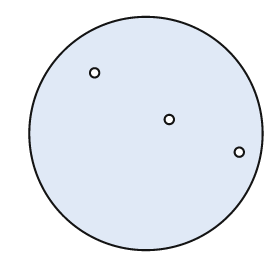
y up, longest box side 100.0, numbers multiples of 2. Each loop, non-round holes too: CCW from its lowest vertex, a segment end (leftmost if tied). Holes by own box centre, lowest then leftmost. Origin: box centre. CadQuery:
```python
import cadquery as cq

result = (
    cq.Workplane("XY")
    .moveTo(0.0, 0.0)
    .circle(50.0)
    .moveTo(40.0, -8.0)
    .circle(2.0)
    .moveTo(10.0, 6.0)
    .circle(2.0)
    .moveTo(-22.0, 26.0)
    .circle(2.0)
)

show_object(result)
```